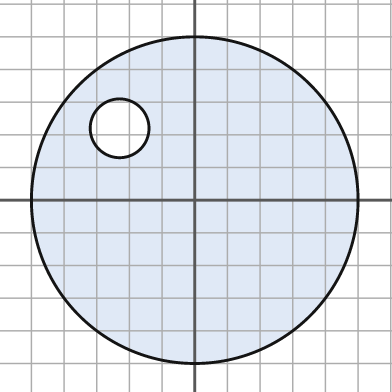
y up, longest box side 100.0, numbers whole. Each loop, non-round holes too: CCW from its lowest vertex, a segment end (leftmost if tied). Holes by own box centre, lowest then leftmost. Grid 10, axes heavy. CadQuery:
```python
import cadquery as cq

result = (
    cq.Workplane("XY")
    .moveTo(0.0, 0.0)
    .circle(50.0)
    .moveTo(-23.0, 22.0)
    .circle(9.0)
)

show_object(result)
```